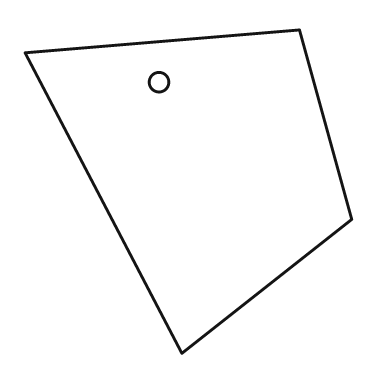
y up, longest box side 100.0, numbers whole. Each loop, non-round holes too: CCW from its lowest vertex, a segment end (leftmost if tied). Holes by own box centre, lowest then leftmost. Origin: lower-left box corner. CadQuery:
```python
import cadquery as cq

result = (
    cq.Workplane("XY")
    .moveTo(48.0, 0.0)
    .lineTo(100.0, 41.0)
    .lineTo(84.0, 99.0)
    .lineTo(0.0, 92.0)
    .close()
    .moveTo(41.0, 83.0)
    .circle(3.0)
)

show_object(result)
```